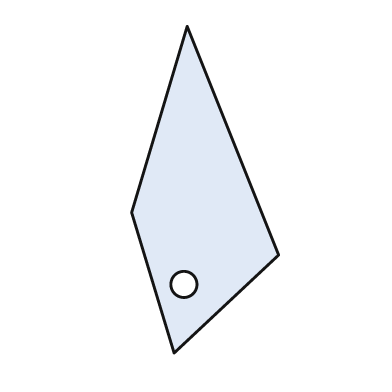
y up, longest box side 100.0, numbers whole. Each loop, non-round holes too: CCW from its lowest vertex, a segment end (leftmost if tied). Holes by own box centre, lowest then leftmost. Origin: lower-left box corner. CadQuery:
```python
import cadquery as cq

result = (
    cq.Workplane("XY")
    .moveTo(13.0, 0.0)
    .lineTo(45.0, 30.0)
    .lineTo(17.0, 100.0)
    .lineTo(0.0, 43.0)
    .close()
    .moveTo(16.0, 21.0)
    .circle(4.0)
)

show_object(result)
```